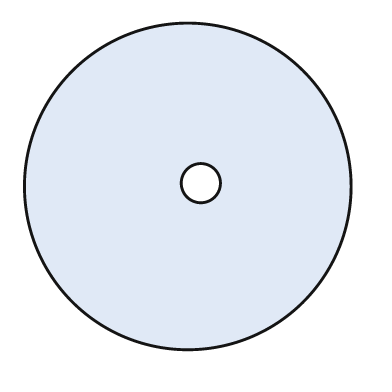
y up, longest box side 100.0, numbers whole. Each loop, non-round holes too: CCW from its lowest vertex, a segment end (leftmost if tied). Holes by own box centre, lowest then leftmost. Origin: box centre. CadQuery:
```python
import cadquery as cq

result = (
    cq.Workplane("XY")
    .moveTo(0.0, 0.0)
    .circle(50.0)
    .moveTo(4.0, 1.0)
    .circle(6.0)
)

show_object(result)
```